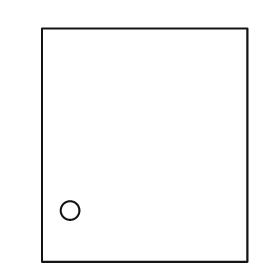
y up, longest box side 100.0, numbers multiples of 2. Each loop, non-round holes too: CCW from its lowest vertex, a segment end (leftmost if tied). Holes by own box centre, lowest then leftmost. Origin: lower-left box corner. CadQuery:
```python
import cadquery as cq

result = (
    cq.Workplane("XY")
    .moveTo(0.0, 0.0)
    .lineTo(88.0, 0.0)
    .lineTo(88.0, 100.0)
    .lineTo(0.0, 100.0)
    .close()
    .moveTo(12.0, 22.0)
    .circle(4.0)
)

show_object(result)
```